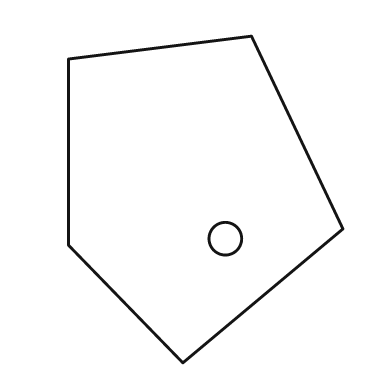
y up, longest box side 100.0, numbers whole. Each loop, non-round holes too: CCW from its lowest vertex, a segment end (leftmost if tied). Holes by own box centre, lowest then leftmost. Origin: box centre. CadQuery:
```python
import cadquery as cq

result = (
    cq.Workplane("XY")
    .moveTo(-7.0, -50.0)
    .lineTo(42.0, -9.0)
    .lineTo(14.0, 50.0)
    .lineTo(-42.0, 43.0)
    .lineTo(-42.0, -14.0)
    .close()
    .moveTo(6.0, -12.0)
    .circle(5.0)
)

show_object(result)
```